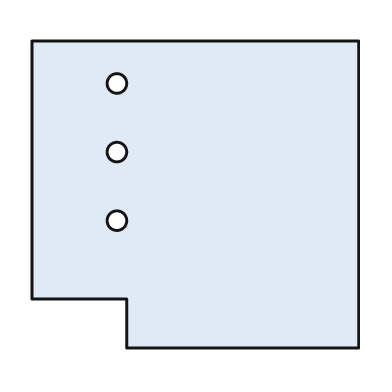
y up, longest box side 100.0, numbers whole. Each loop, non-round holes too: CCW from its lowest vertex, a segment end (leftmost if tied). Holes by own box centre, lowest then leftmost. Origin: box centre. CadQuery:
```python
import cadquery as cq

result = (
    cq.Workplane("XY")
    .moveTo(-21.0, -47.0)
    .lineTo(50.0, -47.0)
    .lineTo(50.0, 47.0)
    .lineTo(-50.0, 47.0)
    .lineTo(-50.0, -32.0)
    .lineTo(-21.0, -32.0)
    .close()
    .moveTo(-24.0, -8.0)
    .circle(3.0)
    .moveTo(-24.0, 13.0)
    .circle(3.0)
    .moveTo(-24.0, 34.0)
    .circle(3.0)
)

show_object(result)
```